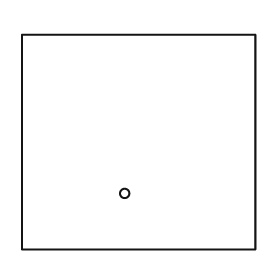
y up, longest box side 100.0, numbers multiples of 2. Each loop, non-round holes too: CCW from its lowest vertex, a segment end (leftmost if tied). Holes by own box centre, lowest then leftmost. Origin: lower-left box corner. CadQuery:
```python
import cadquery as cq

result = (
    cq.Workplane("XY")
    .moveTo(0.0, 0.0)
    .lineTo(100.0, 0.0)
    .lineTo(100.0, 92.0)
    .lineTo(0.0, 92.0)
    .close()
    .moveTo(44.0, 24.0)
    .circle(2.0)
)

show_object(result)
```